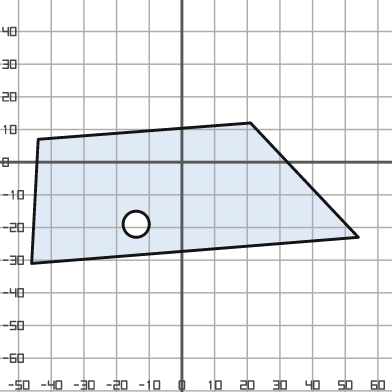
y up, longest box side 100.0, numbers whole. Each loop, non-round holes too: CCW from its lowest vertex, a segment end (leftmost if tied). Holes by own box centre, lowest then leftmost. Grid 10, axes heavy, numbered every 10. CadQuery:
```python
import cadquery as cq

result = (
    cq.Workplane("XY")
    .moveTo(-46.0, -31.0)
    .lineTo(54.0, -23.0)
    .lineTo(21.0, 12.0)
    .lineTo(-44.0, 7.0)
    .close()
    .moveTo(-14.0, -19.0)
    .circle(4.0)
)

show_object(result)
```